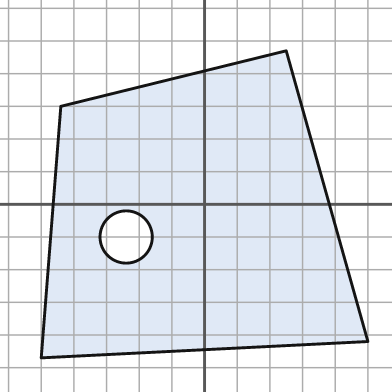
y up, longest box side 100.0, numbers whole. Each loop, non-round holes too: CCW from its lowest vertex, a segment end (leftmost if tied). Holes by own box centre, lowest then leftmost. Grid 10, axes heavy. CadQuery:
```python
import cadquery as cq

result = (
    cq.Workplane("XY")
    .moveTo(-50.0, -47.0)
    .lineTo(50.0, -42.0)
    .lineTo(25.0, 47.0)
    .lineTo(-44.0, 30.0)
    .close()
    .moveTo(-24.0, -10.0)
    .circle(8.0)
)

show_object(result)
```